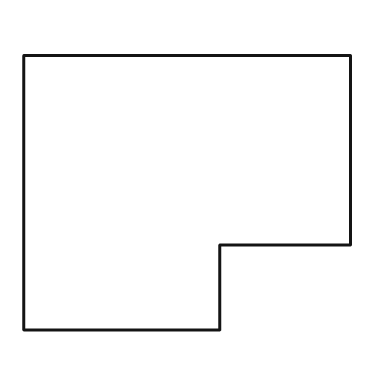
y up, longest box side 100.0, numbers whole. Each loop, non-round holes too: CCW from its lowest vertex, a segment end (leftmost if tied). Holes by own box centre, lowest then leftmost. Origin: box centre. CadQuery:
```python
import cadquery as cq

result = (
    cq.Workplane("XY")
    .moveTo(-50.0, -42.0)
    .lineTo(10.0, -42.0)
    .lineTo(10.0, -16.0)
    .lineTo(50.0, -16.0)
    .lineTo(50.0, 42.0)
    .lineTo(-50.0, 42.0)
    .close()
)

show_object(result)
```